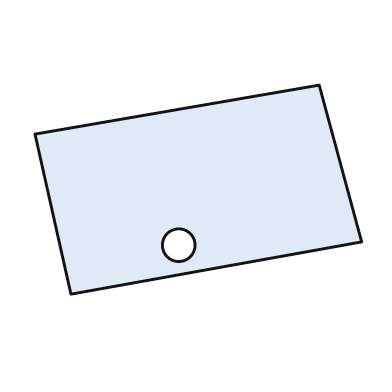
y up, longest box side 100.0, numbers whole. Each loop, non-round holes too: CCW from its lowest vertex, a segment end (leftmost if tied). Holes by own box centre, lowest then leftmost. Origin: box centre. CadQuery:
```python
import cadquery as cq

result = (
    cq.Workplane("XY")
    .moveTo(-39.0, -32.0)
    .lineTo(50.0, -16.0)
    .lineTo(37.0, 32.0)
    .lineTo(-50.0, 17.0)
    .close()
    .moveTo(-6.0, -17.0)
    .circle(5.0)
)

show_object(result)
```